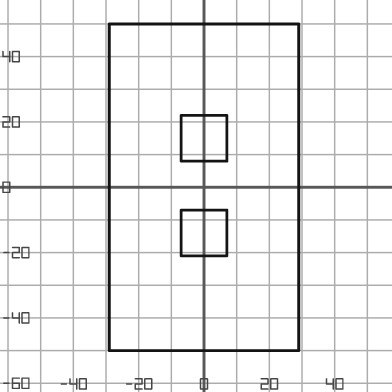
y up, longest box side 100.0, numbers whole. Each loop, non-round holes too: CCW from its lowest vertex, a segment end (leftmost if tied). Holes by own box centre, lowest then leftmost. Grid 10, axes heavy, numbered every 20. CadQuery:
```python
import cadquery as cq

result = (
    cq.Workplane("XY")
    .moveTo(-29.0, -50.0)
    .lineTo(29.0, -50.0)
    .lineTo(29.0, 50.0)
    .lineTo(-29.0, 50.0)
    .close()
    .moveTo(-7.0, -21.0)
    .lineTo(7.0, -21.0)
    .lineTo(7.0, -7.0)
    .lineTo(-7.0, -7.0)
    .close()
    .moveTo(-7.0, 8.0)
    .lineTo(7.0, 8.0)
    .lineTo(7.0, 22.0)
    .lineTo(-7.0, 22.0)
    .close()
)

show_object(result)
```